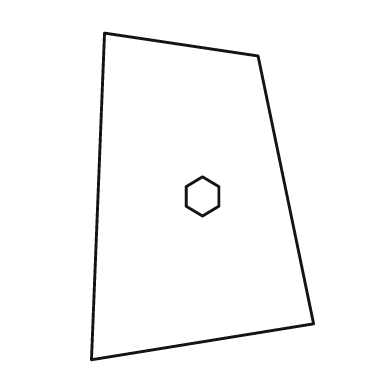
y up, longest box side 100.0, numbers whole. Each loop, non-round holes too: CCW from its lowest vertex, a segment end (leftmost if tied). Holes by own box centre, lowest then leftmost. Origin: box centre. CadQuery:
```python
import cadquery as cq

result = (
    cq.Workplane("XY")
    .moveTo(-34.0, -50.0)
    .lineTo(34.0, -39.0)
    .lineTo(17.0, 43.0)
    .lineTo(-30.0, 50.0)
    .close()
    .moveTo(0.0, -6.0)
    .lineTo(5.0, -3.0)
    .lineTo(5.0, 3.0)
    .lineTo(0.0, 6.0)
    .lineTo(-5.0, 3.0)
    .lineTo(-5.0, -3.0)
    .close()
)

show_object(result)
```